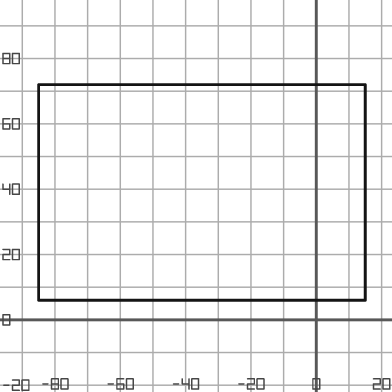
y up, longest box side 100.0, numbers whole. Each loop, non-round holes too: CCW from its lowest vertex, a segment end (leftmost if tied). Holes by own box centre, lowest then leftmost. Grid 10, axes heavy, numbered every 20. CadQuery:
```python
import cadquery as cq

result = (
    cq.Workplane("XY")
    .moveTo(-85.0, 6.0)
    .lineTo(15.0, 6.0)
    .lineTo(15.0, 72.0)
    .lineTo(-85.0, 72.0)
    .close()
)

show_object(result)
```